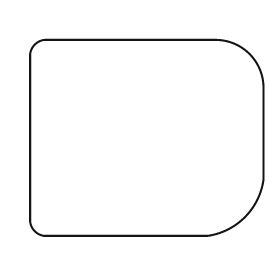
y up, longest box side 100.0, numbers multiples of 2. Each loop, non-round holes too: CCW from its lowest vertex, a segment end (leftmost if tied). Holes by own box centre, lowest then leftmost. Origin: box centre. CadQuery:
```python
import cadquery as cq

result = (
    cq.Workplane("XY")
    .moveTo(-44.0, -42.0)
    .lineTo(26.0, -42.0)
    .threePointArc((42.0, -34.0), (50.0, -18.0))
    .lineTo(50.0, 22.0)
    .threePointArc((44.0, 36.0), (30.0, 42.0))
    .lineTo(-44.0, 42.0)
    .threePointArc((-48.0, 40.0), (-50.0, 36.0))
    .lineTo(-50.0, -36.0)
    .threePointArc((-48.0, -40.0), (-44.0, -42.0))
    .close()
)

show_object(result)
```